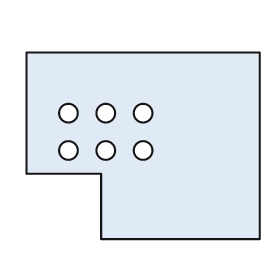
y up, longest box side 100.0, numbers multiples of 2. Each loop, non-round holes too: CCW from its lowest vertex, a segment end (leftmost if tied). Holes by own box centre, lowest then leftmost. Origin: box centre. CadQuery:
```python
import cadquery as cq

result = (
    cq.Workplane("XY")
    .moveTo(-18.0, -40.0)
    .lineTo(50.0, -40.0)
    .lineTo(50.0, 40.0)
    .lineTo(-50.0, 40.0)
    .lineTo(-50.0, -12.0)
    .lineTo(-18.0, -12.0)
    .close()
    .moveTo(-32.0, -2.0)
    .circle(4.0)
    .moveTo(-16.0, -2.0)
    .circle(4.0)
    .moveTo(0.0, -2.0)
    .circle(4.0)
    .moveTo(-32.0, 14.0)
    .circle(4.0)
    .moveTo(-16.0, 14.0)
    .circle(4.0)
    .moveTo(0.0, 14.0)
    .circle(4.0)
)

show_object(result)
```